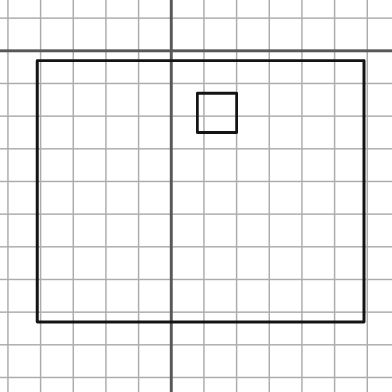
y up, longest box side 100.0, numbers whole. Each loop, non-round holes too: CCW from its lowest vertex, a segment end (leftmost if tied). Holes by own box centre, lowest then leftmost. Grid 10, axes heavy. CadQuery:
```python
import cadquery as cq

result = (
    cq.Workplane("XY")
    .moveTo(-41.0, -83.0)
    .lineTo(59.0, -83.0)
    .lineTo(59.0, -3.0)
    .lineTo(-41.0, -3.0)
    .close()
    .moveTo(8.0, -25.0)
    .lineTo(20.0, -25.0)
    .lineTo(20.0, -13.0)
    .lineTo(8.0, -13.0)
    .close()
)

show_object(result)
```